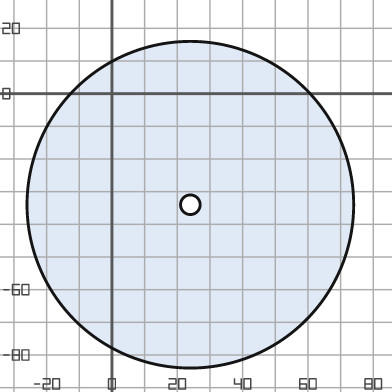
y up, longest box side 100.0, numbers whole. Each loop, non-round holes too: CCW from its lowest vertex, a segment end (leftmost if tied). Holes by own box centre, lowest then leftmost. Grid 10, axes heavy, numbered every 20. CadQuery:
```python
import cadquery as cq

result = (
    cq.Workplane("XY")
    .moveTo(24.0, -34.0)
    .circle(50.0)
    .moveTo(24.0, -34.0)
    .circle(3.0)
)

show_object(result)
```